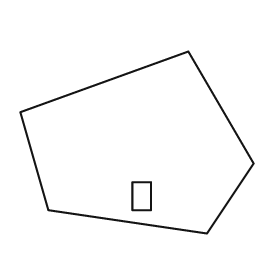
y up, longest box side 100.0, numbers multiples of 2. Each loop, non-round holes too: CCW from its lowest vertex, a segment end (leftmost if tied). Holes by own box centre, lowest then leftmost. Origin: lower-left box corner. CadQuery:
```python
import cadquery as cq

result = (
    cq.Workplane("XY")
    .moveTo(80.0, 0.0)
    .lineTo(100.0, 30.0)
    .lineTo(72.0, 78.0)
    .lineTo(0.0, 52.0)
    .lineTo(12.0, 10.0)
    .close()
    .moveTo(48.0, 10.0)
    .lineTo(56.0, 10.0)
    .lineTo(56.0, 22.0)
    .lineTo(48.0, 22.0)
    .close()
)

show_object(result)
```